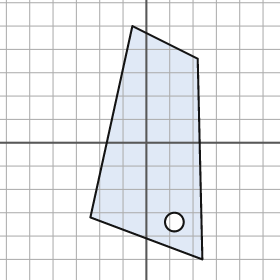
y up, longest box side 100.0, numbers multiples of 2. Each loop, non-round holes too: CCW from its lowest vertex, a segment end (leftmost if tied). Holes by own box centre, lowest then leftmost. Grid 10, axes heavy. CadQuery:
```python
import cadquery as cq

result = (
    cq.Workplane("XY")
    .moveTo(24.0, -50.0)
    .lineTo(22.0, 36.0)
    .lineTo(-6.0, 50.0)
    .lineTo(-24.0, -32.0)
    .close()
    .moveTo(12.0, -34.0)
    .circle(4.0)
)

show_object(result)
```